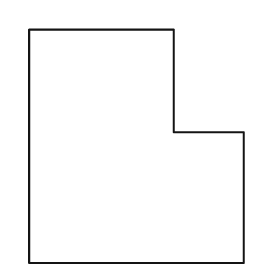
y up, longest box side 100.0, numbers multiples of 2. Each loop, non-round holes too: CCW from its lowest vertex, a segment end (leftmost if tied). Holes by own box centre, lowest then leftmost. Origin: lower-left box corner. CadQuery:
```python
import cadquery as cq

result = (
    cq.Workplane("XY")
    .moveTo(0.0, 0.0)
    .lineTo(92.0, 0.0)
    .lineTo(92.0, 56.0)
    .lineTo(62.0, 56.0)
    .lineTo(62.0, 100.0)
    .lineTo(0.0, 100.0)
    .close()
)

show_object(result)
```